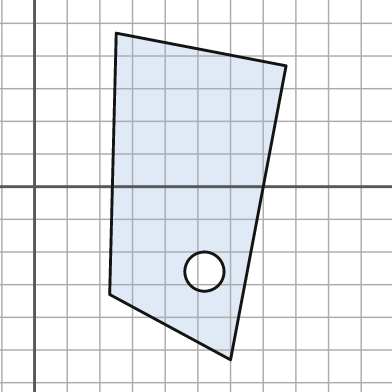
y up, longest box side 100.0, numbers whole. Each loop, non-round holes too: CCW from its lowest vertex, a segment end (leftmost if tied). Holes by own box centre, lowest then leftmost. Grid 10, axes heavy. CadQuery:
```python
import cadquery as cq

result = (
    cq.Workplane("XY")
    .moveTo(60.0, -53.0)
    .lineTo(77.0, 37.0)
    .lineTo(25.0, 47.0)
    .lineTo(23.0, -33.0)
    .close()
    .moveTo(52.0, -26.0)
    .circle(6.0)
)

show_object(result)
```